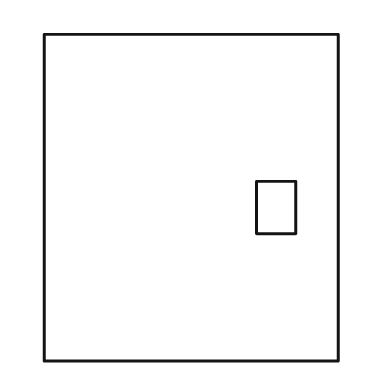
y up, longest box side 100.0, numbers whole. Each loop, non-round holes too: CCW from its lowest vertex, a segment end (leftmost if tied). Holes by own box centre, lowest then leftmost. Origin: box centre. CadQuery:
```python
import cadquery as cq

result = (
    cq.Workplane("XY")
    .moveTo(-45.0, -50.0)
    .lineTo(45.0, -50.0)
    .lineTo(45.0, 50.0)
    .lineTo(-45.0, 50.0)
    .close()
    .moveTo(20.0, -11.0)
    .lineTo(32.0, -11.0)
    .lineTo(32.0, 5.0)
    .lineTo(20.0, 5.0)
    .close()
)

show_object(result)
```